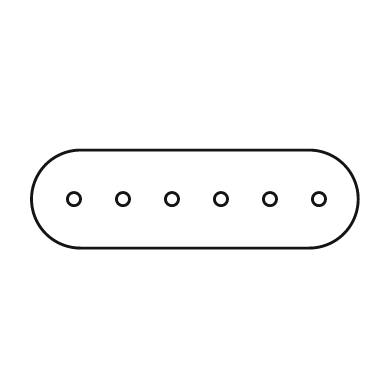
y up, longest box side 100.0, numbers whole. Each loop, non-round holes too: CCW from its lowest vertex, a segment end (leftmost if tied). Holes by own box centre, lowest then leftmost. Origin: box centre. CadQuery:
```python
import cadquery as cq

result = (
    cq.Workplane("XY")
    .moveTo(-35.0, -15.0)
    .lineTo(35.0, -15.0)
    .threePointArc((50.0, 0.0), (35.0, 15.0))
    .lineTo(-35.0, 15.0)
    .threePointArc((-50.0, 0.0), (-35.0, -15.0))
    .close()
    .moveTo(-37.0, 0.0)
    .circle(2.0)
    .moveTo(-22.0, 0.0)
    .circle(2.0)
    .moveTo(-7.0, 0.0)
    .circle(2.0)
    .moveTo(8.0, 0.0)
    .circle(2.0)
    .moveTo(23.0, 0.0)
    .circle(2.0)
    .moveTo(38.0, 0.0)
    .circle(2.0)
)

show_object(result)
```